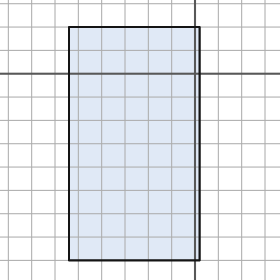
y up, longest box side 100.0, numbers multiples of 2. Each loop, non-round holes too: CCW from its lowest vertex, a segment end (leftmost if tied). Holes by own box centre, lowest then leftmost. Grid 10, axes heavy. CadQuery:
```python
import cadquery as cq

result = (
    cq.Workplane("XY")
    .moveTo(-54.0, -80.0)
    .lineTo(2.0, -80.0)
    .lineTo(2.0, 20.0)
    .lineTo(-54.0, 20.0)
    .close()
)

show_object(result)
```